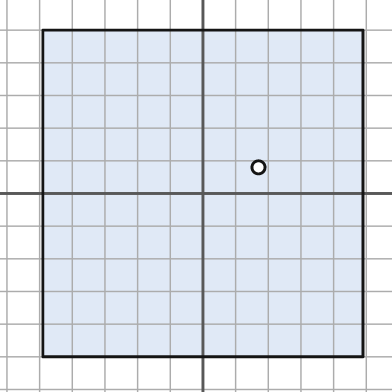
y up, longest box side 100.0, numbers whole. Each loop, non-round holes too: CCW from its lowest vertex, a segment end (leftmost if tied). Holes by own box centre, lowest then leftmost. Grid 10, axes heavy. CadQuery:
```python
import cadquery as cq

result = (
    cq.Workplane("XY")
    .moveTo(-49.0, -50.0)
    .lineTo(49.0, -50.0)
    .lineTo(49.0, 50.0)
    .lineTo(-49.0, 50.0)
    .close()
    .moveTo(17.0, 8.0)
    .circle(2.0)
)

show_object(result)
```